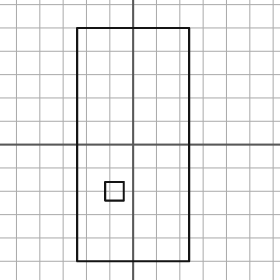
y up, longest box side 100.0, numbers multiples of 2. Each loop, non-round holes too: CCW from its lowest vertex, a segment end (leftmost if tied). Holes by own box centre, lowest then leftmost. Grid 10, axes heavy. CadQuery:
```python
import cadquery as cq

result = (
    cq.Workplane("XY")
    .moveTo(-24.0, -50.0)
    .lineTo(24.0, -50.0)
    .lineTo(24.0, 50.0)
    .lineTo(-24.0, 50.0)
    .close()
    .moveTo(-12.0, -24.0)
    .lineTo(-4.0, -24.0)
    .lineTo(-4.0, -16.0)
    .lineTo(-12.0, -16.0)
    .close()
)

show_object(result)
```